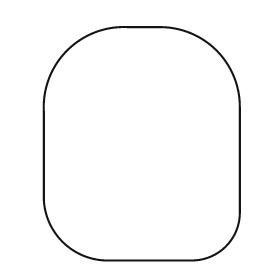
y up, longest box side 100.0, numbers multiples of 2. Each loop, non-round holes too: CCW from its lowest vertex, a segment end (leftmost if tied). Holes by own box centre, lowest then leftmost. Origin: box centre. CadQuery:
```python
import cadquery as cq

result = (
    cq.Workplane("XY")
    .moveTo(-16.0, -50.0)
    .lineTo(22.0, -50.0)
    .threePointArc((36.0, -44.0), (42.0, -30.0))
    .lineTo(42.0, 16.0)
    .threePointArc((32.0, 40.0), (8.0, 50.0))
    .lineTo(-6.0, 50.0)
    .threePointArc((-32.0, 40.0), (-42.0, 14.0))
    .lineTo(-42.0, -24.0)
    .threePointArc((-34.0, -42.0), (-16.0, -50.0))
    .close()
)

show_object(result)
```